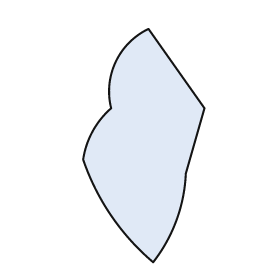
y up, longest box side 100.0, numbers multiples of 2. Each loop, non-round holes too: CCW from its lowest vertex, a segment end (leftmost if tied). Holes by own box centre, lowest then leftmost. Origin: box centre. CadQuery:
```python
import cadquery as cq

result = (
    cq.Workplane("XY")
    .moveTo(4.0, -50.0)
    .threePointArc((14.0, -32.0), (18.0, -12.0))
    .lineTo(26.0, 16.0)
    .lineTo(2.0, 50.0)
    .threePointArc((-12.0, 36.0), (-14.0, 16.0))
    .threePointArc((-22.0, 6.0), (-26.0, -6.0))
    .threePointArc((-14.0, -30.0), (4.0, -50.0))
    .close()
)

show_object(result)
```